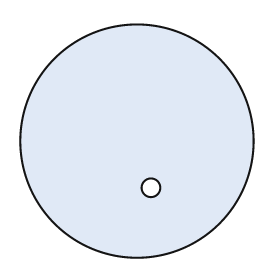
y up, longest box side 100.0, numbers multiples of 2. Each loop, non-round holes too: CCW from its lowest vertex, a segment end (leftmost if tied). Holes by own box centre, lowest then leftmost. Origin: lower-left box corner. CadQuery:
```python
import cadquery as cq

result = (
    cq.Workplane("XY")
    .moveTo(50.0, 50.0)
    .circle(50.0)
    .moveTo(56.0, 30.0)
    .circle(4.0)
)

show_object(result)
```